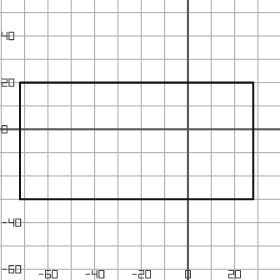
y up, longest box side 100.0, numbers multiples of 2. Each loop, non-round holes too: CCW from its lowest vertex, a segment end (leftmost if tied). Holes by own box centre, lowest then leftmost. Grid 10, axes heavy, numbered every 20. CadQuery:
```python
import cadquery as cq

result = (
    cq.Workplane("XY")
    .moveTo(-72.0, -30.0)
    .lineTo(28.0, -30.0)
    .lineTo(28.0, 20.0)
    .lineTo(-72.0, 20.0)
    .close()
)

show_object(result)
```